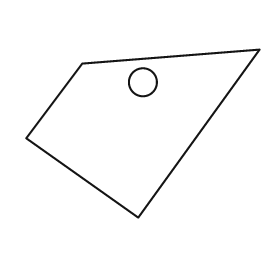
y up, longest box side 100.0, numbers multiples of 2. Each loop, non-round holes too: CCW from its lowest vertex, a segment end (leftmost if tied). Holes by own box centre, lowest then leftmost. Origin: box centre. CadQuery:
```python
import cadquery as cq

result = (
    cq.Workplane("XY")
    .moveTo(-2.0, -36.0)
    .lineTo(50.0, 36.0)
    .lineTo(-26.0, 30.0)
    .lineTo(-50.0, -2.0)
    .close()
    .moveTo(0.0, 22.0)
    .circle(6.0)
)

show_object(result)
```